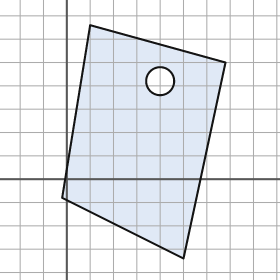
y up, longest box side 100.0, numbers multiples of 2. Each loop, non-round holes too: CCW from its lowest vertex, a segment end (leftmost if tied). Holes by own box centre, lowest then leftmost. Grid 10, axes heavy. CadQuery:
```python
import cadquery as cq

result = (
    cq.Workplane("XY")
    .moveTo(50.0, -34.0)
    .lineTo(68.0, 50.0)
    .lineTo(10.0, 66.0)
    .lineTo(-2.0, -8.0)
    .close()
    .moveTo(40.0, 42.0)
    .circle(6.0)
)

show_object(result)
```